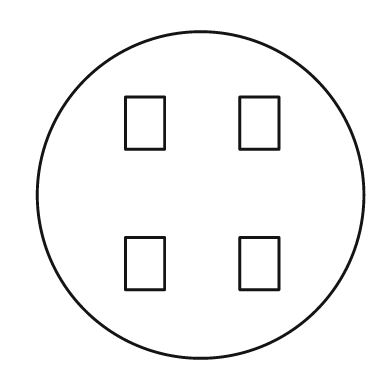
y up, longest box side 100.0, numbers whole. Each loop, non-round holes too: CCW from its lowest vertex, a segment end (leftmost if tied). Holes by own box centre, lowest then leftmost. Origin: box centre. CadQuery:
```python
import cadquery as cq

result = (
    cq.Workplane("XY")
    .moveTo(0.0, 0.0)
    .circle(50.0)
    .moveTo(-23.0, -29.0)
    .lineTo(-11.0, -29.0)
    .lineTo(-11.0, -13.0)
    .lineTo(-23.0, -13.0)
    .close()
    .moveTo(12.0, -29.0)
    .lineTo(24.0, -29.0)
    .lineTo(24.0, -13.0)
    .lineTo(12.0, -13.0)
    .close()
    .moveTo(-23.0, 14.0)
    .lineTo(-11.0, 14.0)
    .lineTo(-11.0, 30.0)
    .lineTo(-23.0, 30.0)
    .close()
    .moveTo(12.0, 14.0)
    .lineTo(24.0, 14.0)
    .lineTo(24.0, 30.0)
    .lineTo(12.0, 30.0)
    .close()
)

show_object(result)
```